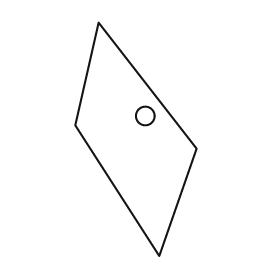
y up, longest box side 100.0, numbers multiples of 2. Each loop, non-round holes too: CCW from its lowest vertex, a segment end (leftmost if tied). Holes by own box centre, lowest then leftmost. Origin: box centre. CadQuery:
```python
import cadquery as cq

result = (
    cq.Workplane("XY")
    .moveTo(10.0, -50.0)
    .lineTo(26.0, -4.0)
    .lineTo(-16.0, 50.0)
    .lineTo(-26.0, 6.0)
    .close()
    .moveTo(4.0, 10.0)
    .circle(4.0)
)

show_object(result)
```